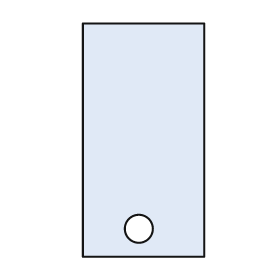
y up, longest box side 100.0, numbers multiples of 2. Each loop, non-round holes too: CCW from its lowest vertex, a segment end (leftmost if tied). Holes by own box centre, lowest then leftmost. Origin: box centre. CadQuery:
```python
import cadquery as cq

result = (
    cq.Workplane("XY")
    .moveTo(-26.0, -50.0)
    .lineTo(26.0, -50.0)
    .lineTo(26.0, 50.0)
    .lineTo(-26.0, 50.0)
    .close()
    .moveTo(-2.0, -38.0)
    .circle(6.0)
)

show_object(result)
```